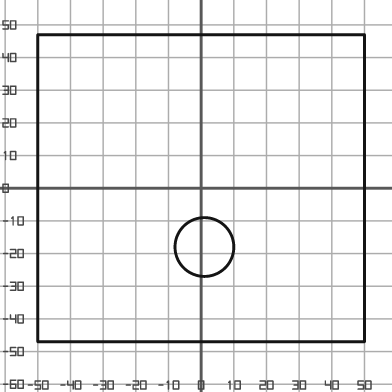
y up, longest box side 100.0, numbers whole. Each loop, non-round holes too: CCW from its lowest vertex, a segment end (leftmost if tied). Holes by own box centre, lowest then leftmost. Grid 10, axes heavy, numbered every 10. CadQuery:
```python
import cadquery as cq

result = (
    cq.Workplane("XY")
    .moveTo(-50.0, -47.0)
    .lineTo(50.0, -47.0)
    .lineTo(50.0, 47.0)
    .lineTo(-50.0, 47.0)
    .close()
    .moveTo(1.0, -18.0)
    .circle(9.0)
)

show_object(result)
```